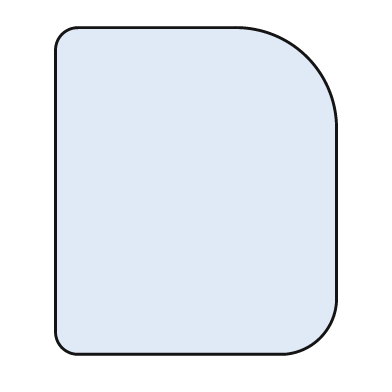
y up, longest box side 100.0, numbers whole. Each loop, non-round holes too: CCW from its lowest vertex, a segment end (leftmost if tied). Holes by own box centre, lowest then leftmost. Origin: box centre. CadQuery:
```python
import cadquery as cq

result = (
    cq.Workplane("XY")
    .moveTo(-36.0, -50.0)
    .lineTo(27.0, -50.0)
    .threePointArc((38.0, -45.0), (43.0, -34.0))
    .lineTo(43.0, 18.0)
    .threePointArc((34.0, 41.0), (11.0, 50.0))
    .lineTo(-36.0, 50.0)
    .threePointArc((-41.0, 48.0), (-43.0, 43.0))
    .lineTo(-43.0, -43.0)
    .threePointArc((-41.0, -48.0), (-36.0, -50.0))
    .close()
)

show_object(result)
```